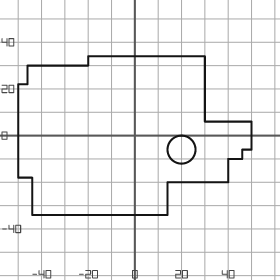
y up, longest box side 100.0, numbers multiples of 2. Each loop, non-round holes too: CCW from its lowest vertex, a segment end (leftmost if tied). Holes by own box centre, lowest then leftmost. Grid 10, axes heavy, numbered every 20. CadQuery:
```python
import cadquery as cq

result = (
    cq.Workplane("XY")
    .moveTo(-44.0, -34.0)
    .lineTo(14.0, -34.0)
    .lineTo(14.0, -20.0)
    .lineTo(40.0, -20.0)
    .lineTo(40.0, -10.0)
    .lineTo(46.0, -10.0)
    .lineTo(46.0, -6.0)
    .lineTo(50.0, -6.0)
    .lineTo(50.0, 6.0)
    .lineTo(30.0, 6.0)
    .lineTo(30.0, 34.0)
    .lineTo(-20.0, 34.0)
    .lineTo(-20.0, 30.0)
    .lineTo(-46.0, 30.0)
    .lineTo(-46.0, 22.0)
    .lineTo(-50.0, 22.0)
    .lineTo(-50.0, -18.0)
    .lineTo(-44.0, -18.0)
    .close()
    .moveTo(20.0, -6.0)
    .circle(6.0)
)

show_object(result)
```